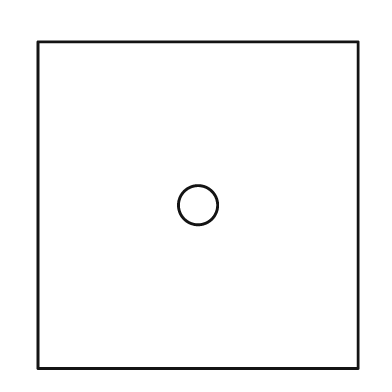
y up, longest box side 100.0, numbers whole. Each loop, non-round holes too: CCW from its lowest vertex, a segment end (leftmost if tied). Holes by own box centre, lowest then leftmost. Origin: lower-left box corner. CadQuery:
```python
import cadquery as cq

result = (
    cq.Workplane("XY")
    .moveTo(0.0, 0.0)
    .lineTo(98.0, 0.0)
    .lineTo(98.0, 100.0)
    .lineTo(0.0, 100.0)
    .close()
    .moveTo(49.0, 50.0)
    .circle(6.0)
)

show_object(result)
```